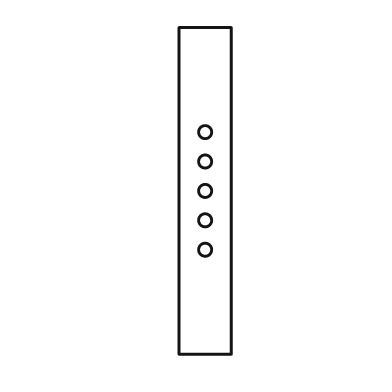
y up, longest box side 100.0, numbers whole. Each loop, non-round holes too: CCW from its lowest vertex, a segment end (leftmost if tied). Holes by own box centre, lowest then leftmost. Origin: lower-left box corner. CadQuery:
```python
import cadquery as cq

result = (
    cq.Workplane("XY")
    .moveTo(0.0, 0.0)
    .lineTo(16.0, 0.0)
    .lineTo(16.0, 100.0)
    .lineTo(0.0, 100.0)
    .close()
    .moveTo(8.0, 32.0)
    .circle(2.0)
    .moveTo(8.0, 41.0)
    .circle(2.0)
    .moveTo(8.0, 50.0)
    .circle(2.0)
    .moveTo(8.0, 59.0)
    .circle(2.0)
    .moveTo(8.0, 68.0)
    .circle(2.0)
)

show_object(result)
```